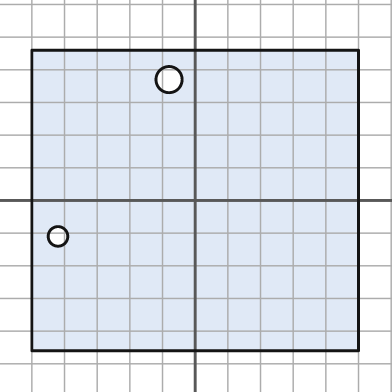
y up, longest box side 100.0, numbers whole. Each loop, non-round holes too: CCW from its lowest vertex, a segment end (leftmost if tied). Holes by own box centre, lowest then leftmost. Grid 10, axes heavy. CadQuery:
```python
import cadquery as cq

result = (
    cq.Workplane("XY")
    .moveTo(-50.0, -46.0)
    .lineTo(50.0, -46.0)
    .lineTo(50.0, 46.0)
    .lineTo(-50.0, 46.0)
    .close()
    .moveTo(-42.0, -11.0)
    .circle(3.0)
    .moveTo(-8.0, 37.0)
    .circle(4.0)
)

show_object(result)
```